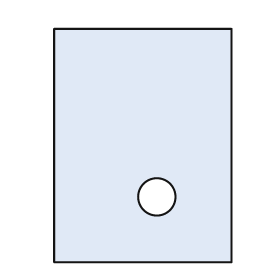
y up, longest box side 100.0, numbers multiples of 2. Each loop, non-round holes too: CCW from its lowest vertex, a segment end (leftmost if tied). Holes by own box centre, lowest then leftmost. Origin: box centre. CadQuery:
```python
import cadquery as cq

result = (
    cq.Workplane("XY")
    .moveTo(-38.0, -50.0)
    .lineTo(38.0, -50.0)
    .lineTo(38.0, 50.0)
    .lineTo(-38.0, 50.0)
    .close()
    .moveTo(6.0, -22.0)
    .circle(8.0)
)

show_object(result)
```